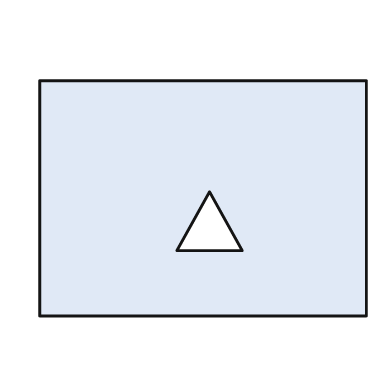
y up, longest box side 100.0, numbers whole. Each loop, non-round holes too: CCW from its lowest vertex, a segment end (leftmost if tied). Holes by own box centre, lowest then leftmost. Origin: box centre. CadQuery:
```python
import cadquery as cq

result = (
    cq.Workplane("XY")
    .moveTo(-50.0, -36.0)
    .lineTo(50.0, -36.0)
    .lineTo(50.0, 36.0)
    .lineTo(-50.0, 36.0)
    .close()
    .moveTo(-8.0, -16.0)
    .lineTo(12.0, -16.0)
    .lineTo(2.0, 2.0)
    .close()
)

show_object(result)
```